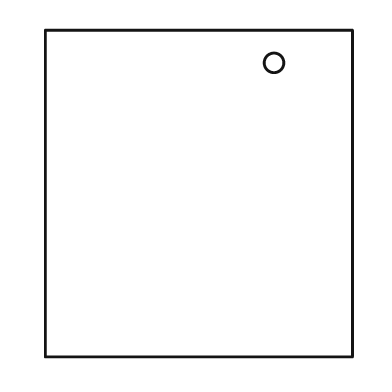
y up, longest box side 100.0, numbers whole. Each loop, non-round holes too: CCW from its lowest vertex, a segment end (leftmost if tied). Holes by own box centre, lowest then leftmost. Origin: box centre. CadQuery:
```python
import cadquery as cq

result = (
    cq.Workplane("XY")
    .moveTo(-47.0, -50.0)
    .lineTo(47.0, -50.0)
    .lineTo(47.0, 50.0)
    .lineTo(-47.0, 50.0)
    .close()
    .moveTo(23.0, 40.0)
    .circle(3.0)
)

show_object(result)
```